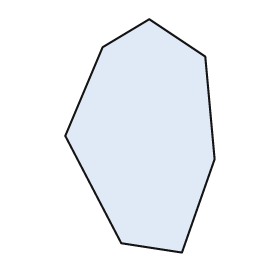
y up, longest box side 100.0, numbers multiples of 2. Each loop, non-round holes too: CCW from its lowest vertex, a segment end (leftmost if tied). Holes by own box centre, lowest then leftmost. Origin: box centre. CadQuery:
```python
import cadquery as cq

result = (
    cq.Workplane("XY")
    .moveTo(18.0, -50.0)
    .lineTo(32.0, -10.0)
    .lineTo(28.0, 34.0)
    .lineTo(4.0, 50.0)
    .lineTo(-16.0, 38.0)
    .lineTo(-32.0, 0.0)
    .lineTo(-8.0, -46.0)
    .close()
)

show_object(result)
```